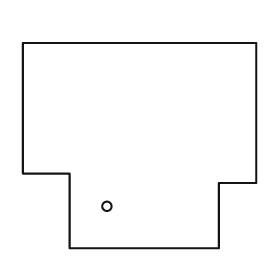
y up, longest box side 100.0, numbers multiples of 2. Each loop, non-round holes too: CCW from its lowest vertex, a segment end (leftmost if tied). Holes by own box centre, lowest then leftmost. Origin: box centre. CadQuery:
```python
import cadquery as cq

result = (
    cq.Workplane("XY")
    .moveTo(-30.0, -44.0)
    .lineTo(34.0, -44.0)
    .lineTo(34.0, -16.0)
    .lineTo(50.0, -16.0)
    .lineTo(50.0, 44.0)
    .lineTo(-50.0, 44.0)
    .lineTo(-50.0, -12.0)
    .lineTo(-30.0, -12.0)
    .close()
    .moveTo(-14.0, -26.0)
    .circle(2.0)
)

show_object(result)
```